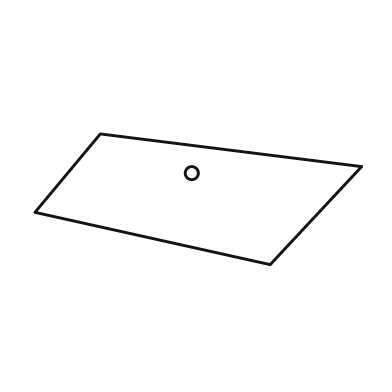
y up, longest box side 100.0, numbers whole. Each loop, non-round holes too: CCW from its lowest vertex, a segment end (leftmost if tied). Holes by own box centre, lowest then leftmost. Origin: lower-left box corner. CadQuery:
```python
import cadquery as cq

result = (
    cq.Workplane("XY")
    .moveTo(72.0, 0.0)
    .lineTo(100.0, 30.0)
    .lineTo(20.0, 40.0)
    .lineTo(0.0, 16.0)
    .close()
    .moveTo(48.0, 28.0)
    .circle(2.0)
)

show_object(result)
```